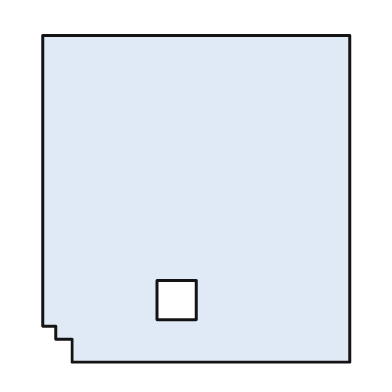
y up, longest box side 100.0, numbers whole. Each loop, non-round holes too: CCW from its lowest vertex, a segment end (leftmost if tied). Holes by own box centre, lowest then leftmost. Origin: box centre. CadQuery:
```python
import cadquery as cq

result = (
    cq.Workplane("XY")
    .moveTo(-38.0, -50.0)
    .lineTo(47.0, -50.0)
    .lineTo(47.0, 50.0)
    .lineTo(-47.0, 50.0)
    .lineTo(-47.0, -39.0)
    .lineTo(-43.0, -39.0)
    .lineTo(-43.0, -43.0)
    .lineTo(-38.0, -43.0)
    .close()
    .moveTo(-12.0, -37.0)
    .lineTo(0.0, -37.0)
    .lineTo(0.0, -25.0)
    .lineTo(-12.0, -25.0)
    .close()
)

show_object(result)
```